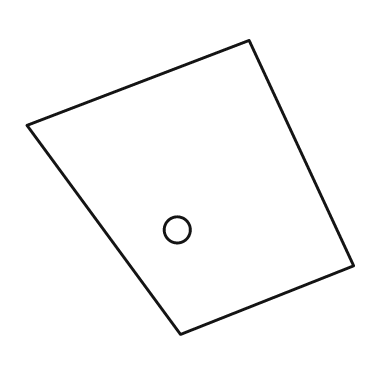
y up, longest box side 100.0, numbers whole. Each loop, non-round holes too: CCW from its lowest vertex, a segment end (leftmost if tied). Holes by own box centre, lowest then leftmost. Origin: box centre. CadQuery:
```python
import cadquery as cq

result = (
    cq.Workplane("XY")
    .moveTo(-3.0, -45.0)
    .lineTo(50.0, -24.0)
    .lineTo(18.0, 45.0)
    .lineTo(-50.0, 19.0)
    .close()
    .moveTo(-4.0, -13.0)
    .circle(4.0)
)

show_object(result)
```